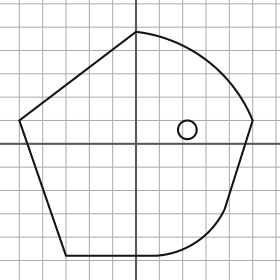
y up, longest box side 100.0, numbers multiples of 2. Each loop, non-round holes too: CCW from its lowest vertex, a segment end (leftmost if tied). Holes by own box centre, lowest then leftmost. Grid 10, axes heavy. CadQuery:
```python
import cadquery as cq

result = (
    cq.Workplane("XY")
    .moveTo(-30.0, -48.0)
    .lineTo(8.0, -48.0)
    .threePointArc((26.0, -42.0), (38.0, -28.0))
    .lineTo(50.0, 10.0)
    .threePointArc((30.0, 36.0), (0.0, 48.0))
    .lineTo(-50.0, 10.0)
    .close()
    .moveTo(22.0, 6.0)
    .circle(4.0)
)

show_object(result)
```